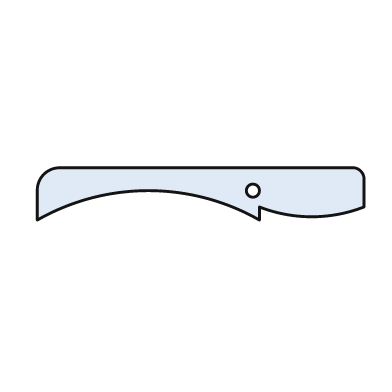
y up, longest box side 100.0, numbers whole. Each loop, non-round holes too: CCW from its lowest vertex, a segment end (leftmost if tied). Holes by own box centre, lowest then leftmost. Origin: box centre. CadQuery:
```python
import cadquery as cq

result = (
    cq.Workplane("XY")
    .moveTo(-50.0, -8.0)
    .threePointArc((-16.0, 1.0), (18.0, -8.0))
    .lineTo(18.0, -4.0)
    .threePointArc((34.0, -7.0), (50.0, -4.0))
    .lineTo(50.0, 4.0)
    .threePointArc((49.0, 7.0), (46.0, 8.0))
    .lineTo(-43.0, 8.0)
    .threePointArc((-48.0, 6.0), (-50.0, 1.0))
    .close()
    .moveTo(16.0, 1.0)
    .circle(2.0)
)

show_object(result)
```